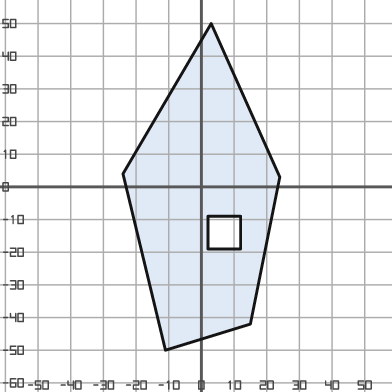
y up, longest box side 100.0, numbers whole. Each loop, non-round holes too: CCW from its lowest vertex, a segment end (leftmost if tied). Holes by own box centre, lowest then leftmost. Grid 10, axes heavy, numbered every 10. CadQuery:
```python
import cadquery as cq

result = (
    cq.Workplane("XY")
    .moveTo(-11.0, -50.0)
    .lineTo(15.0, -42.0)
    .lineTo(24.0, 3.0)
    .lineTo(3.0, 50.0)
    .lineTo(-24.0, 4.0)
    .close()
    .moveTo(2.0, -19.0)
    .lineTo(12.0, -19.0)
    .lineTo(12.0, -9.0)
    .lineTo(2.0, -9.0)
    .close()
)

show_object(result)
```